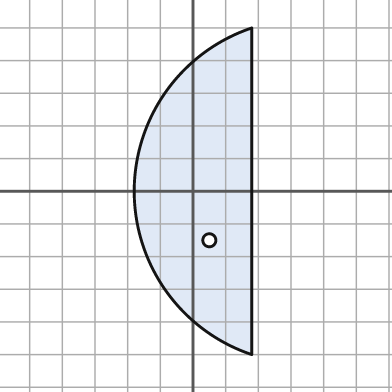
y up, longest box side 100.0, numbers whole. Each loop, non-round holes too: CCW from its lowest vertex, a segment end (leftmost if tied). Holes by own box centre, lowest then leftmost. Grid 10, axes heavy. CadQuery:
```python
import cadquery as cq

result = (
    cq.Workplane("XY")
    .moveTo(18.0, -50.0)
    .lineTo(18.0, 50.0)
    .threePointArc((-18.0, 0.0), (18.0, -50.0))
    .close()
    .moveTo(5.0, -15.0)
    .circle(2.0)
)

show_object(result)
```